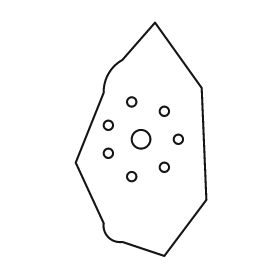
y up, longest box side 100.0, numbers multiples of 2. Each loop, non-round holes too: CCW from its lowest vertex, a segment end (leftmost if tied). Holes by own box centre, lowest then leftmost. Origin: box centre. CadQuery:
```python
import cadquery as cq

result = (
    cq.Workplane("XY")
    .moveTo(10.0, -50.0)
    .lineTo(28.0, -26.0)
    .lineTo(26.0, 22.0)
    .lineTo(6.0, 50.0)
    .lineTo(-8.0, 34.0)
    .threePointArc((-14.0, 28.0), (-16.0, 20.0))
    .lineTo(-28.0, -10.0)
    .lineTo(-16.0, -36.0)
    .threePointArc((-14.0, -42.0), (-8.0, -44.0))
    .close()
    .moveTo(-4.0, -16.0)
    .circle(2.0)
    .moveTo(10.0, -12.0)
    .circle(2.0)
    .moveTo(-14.0, -6.0)
    .circle(2.0)
    .moveTo(0.0, 0.0)
    .circle(4.0)
    .moveTo(16.0, 0.0)
    .circle(2.0)
    .moveTo(-14.0, 6.0)
    .circle(2.0)
    .moveTo(10.0, 12.0)
    .circle(2.0)
    .moveTo(-4.0, 16.0)
    .circle(2.0)
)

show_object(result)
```